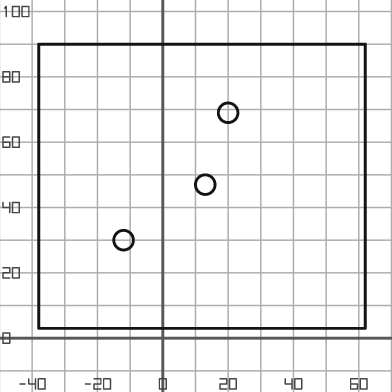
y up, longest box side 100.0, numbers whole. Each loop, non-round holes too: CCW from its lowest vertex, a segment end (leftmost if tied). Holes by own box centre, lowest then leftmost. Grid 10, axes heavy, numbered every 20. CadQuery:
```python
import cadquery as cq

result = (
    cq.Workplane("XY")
    .moveTo(-38.0, 3.0)
    .lineTo(62.0, 3.0)
    .lineTo(62.0, 90.0)
    .lineTo(-38.0, 90.0)
    .close()
    .moveTo(-12.0, 30.0)
    .circle(3.0)
    .moveTo(13.0, 47.0)
    .circle(3.0)
    .moveTo(20.0, 69.0)
    .circle(3.0)
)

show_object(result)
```